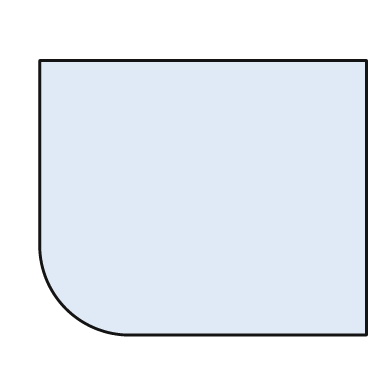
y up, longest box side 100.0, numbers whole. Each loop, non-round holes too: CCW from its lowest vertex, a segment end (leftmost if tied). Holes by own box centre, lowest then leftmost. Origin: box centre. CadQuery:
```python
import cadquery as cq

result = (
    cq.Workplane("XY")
    .moveTo(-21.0, -42.0)
    .lineTo(50.0, -42.0)
    .lineTo(50.0, 42.0)
    .lineTo(-50.0, 42.0)
    .lineTo(-50.0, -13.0)
    .threePointArc((-42.0, -34.0), (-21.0, -42.0))
    .close()
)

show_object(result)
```